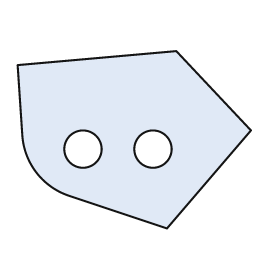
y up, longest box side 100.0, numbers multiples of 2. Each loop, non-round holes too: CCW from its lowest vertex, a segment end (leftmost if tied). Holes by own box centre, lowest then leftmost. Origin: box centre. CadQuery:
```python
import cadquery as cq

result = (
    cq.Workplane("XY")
    .moveTo(14.0, -38.0)
    .lineTo(50.0, 4.0)
    .lineTo(18.0, 38.0)
    .lineTo(-50.0, 32.0)
    .lineTo(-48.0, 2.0)
    .threePointArc((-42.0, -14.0), (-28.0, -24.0))
    .close()
    .moveTo(-22.0, -4.0)
    .circle(8.0)
    .moveTo(8.0, -4.0)
    .circle(8.0)
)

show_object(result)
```